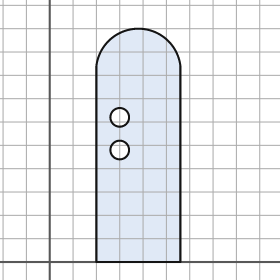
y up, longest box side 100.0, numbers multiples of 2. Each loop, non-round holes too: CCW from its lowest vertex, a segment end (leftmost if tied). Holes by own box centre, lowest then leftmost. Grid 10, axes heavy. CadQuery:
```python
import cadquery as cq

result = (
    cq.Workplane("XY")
    .moveTo(20.0, 0.0)
    .lineTo(56.0, 0.0)
    .lineTo(56.0, 84.0)
    .threePointArc((38.0, 100.0), (20.0, 84.0))
    .close()
    .moveTo(30.0, 48.0)
    .circle(4.0)
    .moveTo(30.0, 62.0)
    .circle(4.0)
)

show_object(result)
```